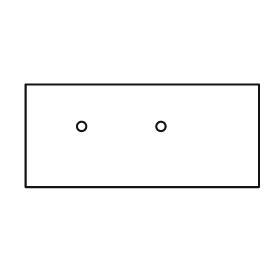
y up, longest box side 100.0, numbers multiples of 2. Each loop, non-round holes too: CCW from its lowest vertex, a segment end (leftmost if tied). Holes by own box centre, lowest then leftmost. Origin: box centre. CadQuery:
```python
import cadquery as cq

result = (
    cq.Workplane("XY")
    .moveTo(-50.0, -22.0)
    .lineTo(50.0, -22.0)
    .lineTo(50.0, 22.0)
    .lineTo(-50.0, 22.0)
    .close()
    .moveTo(-26.0, 4.0)
    .circle(2.0)
    .moveTo(8.0, 4.0)
    .circle(2.0)
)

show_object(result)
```